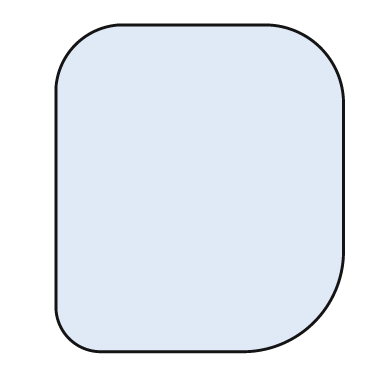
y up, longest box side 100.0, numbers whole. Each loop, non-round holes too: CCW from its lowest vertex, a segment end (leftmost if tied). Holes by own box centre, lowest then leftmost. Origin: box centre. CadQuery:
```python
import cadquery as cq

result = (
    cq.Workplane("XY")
    .moveTo(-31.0, -50.0)
    .lineTo(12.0, -50.0)
    .threePointArc((35.0, -41.0), (44.0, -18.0))
    .lineTo(44.0, 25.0)
    .threePointArc((37.0, 43.0), (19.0, 50.0))
    .lineTo(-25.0, 50.0)
    .threePointArc((-38.0, 44.0), (-44.0, 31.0))
    .lineTo(-44.0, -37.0)
    .threePointArc((-40.0, -46.0), (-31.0, -50.0))
    .close()
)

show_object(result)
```